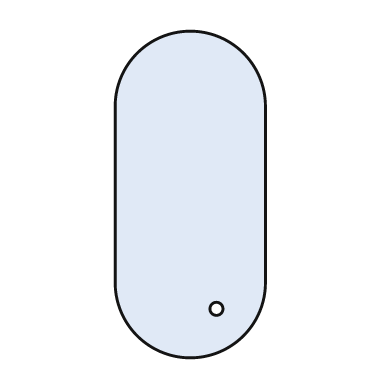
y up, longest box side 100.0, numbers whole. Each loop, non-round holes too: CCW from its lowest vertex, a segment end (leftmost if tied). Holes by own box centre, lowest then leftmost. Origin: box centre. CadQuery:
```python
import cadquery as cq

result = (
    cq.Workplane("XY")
    .moveTo(-23.0, -27.0)
    .threePointArc((0.0, -50.0), (23.0, -27.0))
    .lineTo(23.0, 27.0)
    .threePointArc((0.0, 50.0), (-23.0, 27.0))
    .close()
    .moveTo(8.0, -35.0)
    .circle(2.0)
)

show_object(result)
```